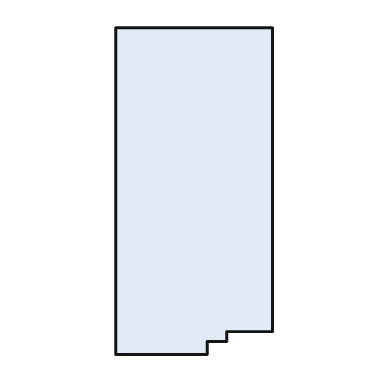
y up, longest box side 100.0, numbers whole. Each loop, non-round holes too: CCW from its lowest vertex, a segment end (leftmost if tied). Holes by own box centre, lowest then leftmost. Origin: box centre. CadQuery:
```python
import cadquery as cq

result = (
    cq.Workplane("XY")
    .moveTo(-24.0, -50.0)
    .lineTo(4.0, -50.0)
    .lineTo(4.0, -46.0)
    .lineTo(10.0, -46.0)
    .lineTo(10.0, -43.0)
    .lineTo(24.0, -43.0)
    .lineTo(24.0, 50.0)
    .lineTo(-24.0, 50.0)
    .close()
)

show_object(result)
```